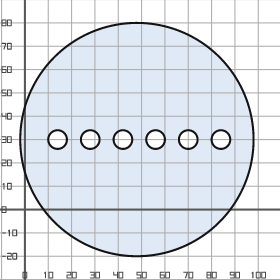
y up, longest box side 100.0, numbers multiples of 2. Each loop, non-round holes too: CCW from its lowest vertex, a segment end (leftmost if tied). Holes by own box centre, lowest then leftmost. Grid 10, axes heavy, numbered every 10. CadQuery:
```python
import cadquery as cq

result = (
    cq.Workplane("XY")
    .moveTo(48.0, 30.0)
    .circle(50.0)
    .moveTo(14.0, 30.0)
    .circle(4.0)
    .moveTo(28.0, 30.0)
    .circle(4.0)
    .moveTo(42.0, 30.0)
    .circle(4.0)
    .moveTo(56.0, 30.0)
    .circle(4.0)
    .moveTo(70.0, 30.0)
    .circle(4.0)
    .moveTo(84.0, 30.0)
    .circle(4.0)
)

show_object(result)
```